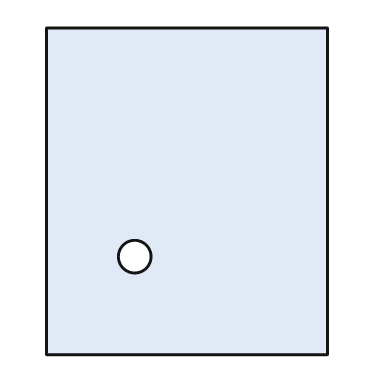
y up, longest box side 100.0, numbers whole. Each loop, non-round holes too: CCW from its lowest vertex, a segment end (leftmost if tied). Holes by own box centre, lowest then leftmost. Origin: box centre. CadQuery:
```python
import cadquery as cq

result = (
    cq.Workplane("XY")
    .moveTo(-43.0, -50.0)
    .lineTo(43.0, -50.0)
    .lineTo(43.0, 50.0)
    .lineTo(-43.0, 50.0)
    .close()
    .moveTo(-16.0, -20.0)
    .circle(5.0)
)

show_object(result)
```